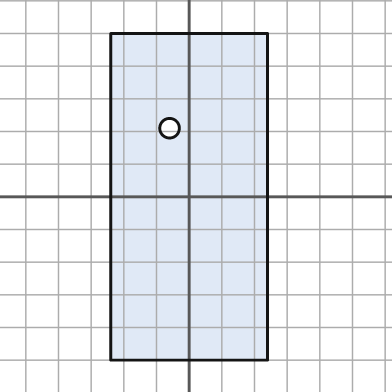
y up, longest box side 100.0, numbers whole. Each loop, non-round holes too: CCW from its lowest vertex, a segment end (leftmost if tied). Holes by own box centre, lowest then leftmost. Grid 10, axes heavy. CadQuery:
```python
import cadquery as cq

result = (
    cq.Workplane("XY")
    .moveTo(-24.0, -50.0)
    .lineTo(24.0, -50.0)
    .lineTo(24.0, 50.0)
    .lineTo(-24.0, 50.0)
    .close()
    .moveTo(-6.0, 21.0)
    .circle(3.0)
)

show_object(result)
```